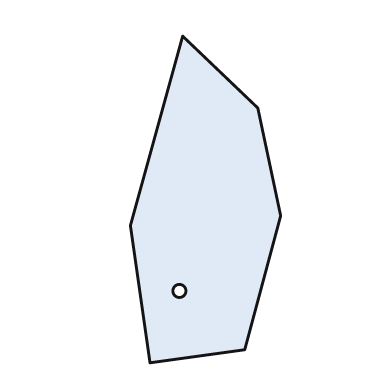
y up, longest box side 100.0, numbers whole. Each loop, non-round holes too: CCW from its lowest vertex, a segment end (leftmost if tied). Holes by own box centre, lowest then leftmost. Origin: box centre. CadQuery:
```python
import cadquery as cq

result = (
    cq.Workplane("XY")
    .moveTo(-17.0, -50.0)
    .lineTo(12.0, -46.0)
    .lineTo(23.0, -5.0)
    .lineTo(16.0, 28.0)
    .lineTo(-7.0, 50.0)
    .lineTo(-23.0, -8.0)
    .close()
    .moveTo(-8.0, -28.0)
    .circle(2.0)
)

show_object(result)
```